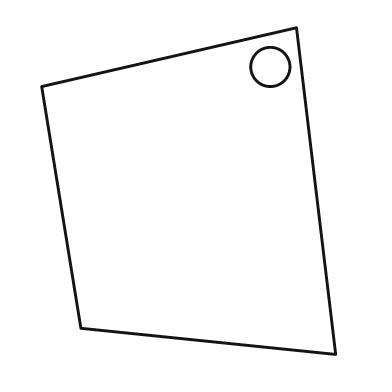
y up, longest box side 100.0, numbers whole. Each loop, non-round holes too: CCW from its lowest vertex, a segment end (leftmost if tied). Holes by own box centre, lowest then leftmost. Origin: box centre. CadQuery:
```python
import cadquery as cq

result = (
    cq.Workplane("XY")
    .moveTo(45.0, -50.0)
    .lineTo(33.0, 50.0)
    .lineTo(-45.0, 32.0)
    .lineTo(-33.0, -42.0)
    .close()
    .moveTo(25.0, 38.0)
    .circle(6.0)
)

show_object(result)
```